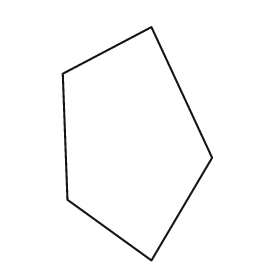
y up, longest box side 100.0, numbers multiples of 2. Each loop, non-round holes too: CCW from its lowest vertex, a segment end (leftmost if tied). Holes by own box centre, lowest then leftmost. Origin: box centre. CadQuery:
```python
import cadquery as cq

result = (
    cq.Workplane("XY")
    .moveTo(6.0, -50.0)
    .lineTo(32.0, -6.0)
    .lineTo(6.0, 50.0)
    .lineTo(-32.0, 30.0)
    .lineTo(-30.0, -24.0)
    .close()
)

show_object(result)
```